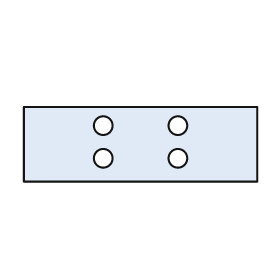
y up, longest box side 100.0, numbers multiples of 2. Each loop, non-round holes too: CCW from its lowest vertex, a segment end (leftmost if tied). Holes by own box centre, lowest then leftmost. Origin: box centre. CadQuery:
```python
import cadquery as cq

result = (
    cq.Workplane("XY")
    .moveTo(-50.0, -16.0)
    .lineTo(50.0, -16.0)
    .lineTo(50.0, 16.0)
    .lineTo(-50.0, 16.0)
    .close()
    .moveTo(-16.0, -6.0)
    .circle(4.0)
    .moveTo(16.0, -6.0)
    .circle(4.0)
    .moveTo(-16.0, 8.0)
    .circle(4.0)
    .moveTo(16.0, 8.0)
    .circle(4.0)
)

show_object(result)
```